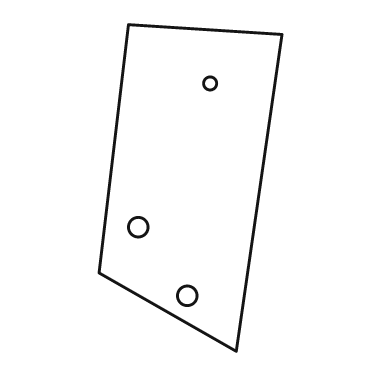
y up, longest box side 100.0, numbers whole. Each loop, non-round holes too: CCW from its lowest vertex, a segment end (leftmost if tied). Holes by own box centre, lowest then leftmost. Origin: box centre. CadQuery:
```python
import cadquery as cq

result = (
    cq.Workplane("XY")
    .moveTo(14.0, -50.0)
    .lineTo(28.0, 47.0)
    .lineTo(-19.0, 50.0)
    .lineTo(-28.0, -26.0)
    .close()
    .moveTo(-1.0, -33.0)
    .circle(3.0)
    .moveTo(-16.0, -12.0)
    .circle(3.0)
    .moveTo(6.0, 32.0)
    .circle(2.0)
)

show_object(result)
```